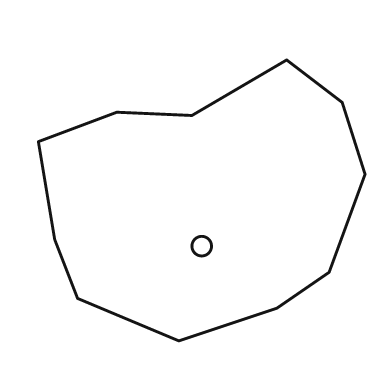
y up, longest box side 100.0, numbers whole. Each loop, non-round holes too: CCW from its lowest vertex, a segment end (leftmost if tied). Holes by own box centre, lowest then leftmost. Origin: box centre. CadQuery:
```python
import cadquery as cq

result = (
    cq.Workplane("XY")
    .moveTo(-7.0, -43.0)
    .lineTo(23.0, -33.0)
    .lineTo(39.0, -22.0)
    .lineTo(50.0, 8.0)
    .lineTo(43.0, 30.0)
    .lineTo(26.0, 43.0)
    .lineTo(-3.0, 26.0)
    .lineTo(-26.0, 27.0)
    .lineTo(-50.0, 18.0)
    .lineTo(-45.0, -12.0)
    .lineTo(-38.0, -30.0)
    .close()
    .moveTo(0.0, -14.0)
    .circle(3.0)
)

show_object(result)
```